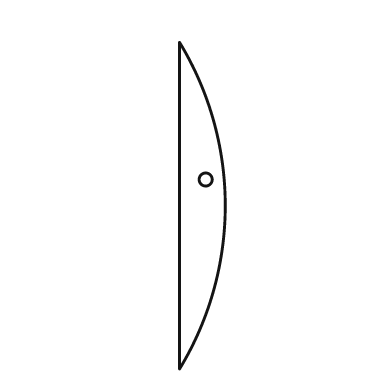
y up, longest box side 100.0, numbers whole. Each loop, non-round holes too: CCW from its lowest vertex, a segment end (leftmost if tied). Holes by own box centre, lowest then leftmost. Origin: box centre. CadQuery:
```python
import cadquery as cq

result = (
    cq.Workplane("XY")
    .moveTo(-7.0, -50.0)
    .threePointArc((7.0, 0.0), (-7.0, 50.0))
    .close()
    .moveTo(1.0, 8.0)
    .circle(2.0)
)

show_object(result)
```